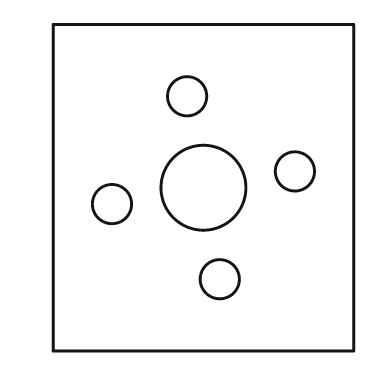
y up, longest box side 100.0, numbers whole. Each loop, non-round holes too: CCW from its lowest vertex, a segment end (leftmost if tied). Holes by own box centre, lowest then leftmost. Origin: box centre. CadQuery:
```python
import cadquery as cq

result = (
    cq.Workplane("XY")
    .moveTo(-46.0, -50.0)
    .lineTo(46.0, -50.0)
    .lineTo(46.0, 50.0)
    .lineTo(-46.0, 50.0)
    .close()
    .moveTo(5.0, -28.0)
    .circle(6.0)
    .moveTo(-28.0, -5.0)
    .circle(6.0)
    .moveTo(0.0, 0.0)
    .circle(13.0)
    .moveTo(28.0, 5.0)
    .circle(6.0)
    .moveTo(-5.0, 28.0)
    .circle(6.0)
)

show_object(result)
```